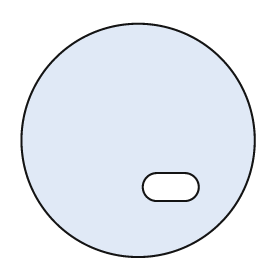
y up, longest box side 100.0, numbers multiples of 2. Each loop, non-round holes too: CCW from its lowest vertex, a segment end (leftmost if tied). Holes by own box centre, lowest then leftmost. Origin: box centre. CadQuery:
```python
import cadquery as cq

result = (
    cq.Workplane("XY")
    .moveTo(0.0, 0.0)
    .circle(50.0)
    .moveTo(8.0, -26.0)
    .lineTo(20.0, -26.0)
    .threePointArc((26.0, -20.0), (20.0, -14.0))
    .lineTo(8.0, -14.0)
    .threePointArc((2.0, -20.0), (8.0, -26.0))
    .close()
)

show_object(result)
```